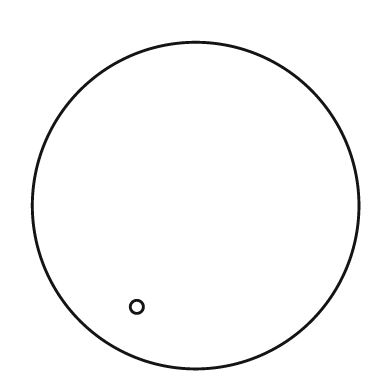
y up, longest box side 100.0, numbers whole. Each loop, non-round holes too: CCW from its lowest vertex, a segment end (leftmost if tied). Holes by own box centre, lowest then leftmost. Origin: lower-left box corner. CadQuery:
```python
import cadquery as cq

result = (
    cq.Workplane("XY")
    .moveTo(50.0, 50.0)
    .circle(50.0)
    .moveTo(32.0, 19.0)
    .circle(2.0)
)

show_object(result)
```